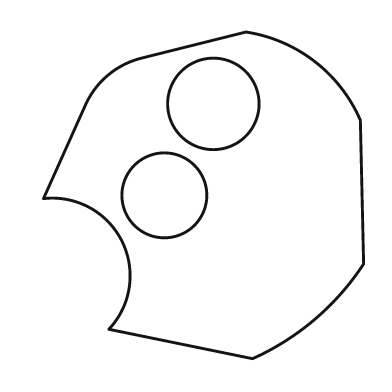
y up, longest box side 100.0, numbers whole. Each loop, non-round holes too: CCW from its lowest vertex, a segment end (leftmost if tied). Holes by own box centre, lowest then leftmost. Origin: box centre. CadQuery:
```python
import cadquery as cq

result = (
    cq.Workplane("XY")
    .moveTo(15.0, -50.0)
    .threePointArc((34.0, -38.0), (49.0, -21.0))
    .lineTo(48.0, 23.0)
    .threePointArc((34.0, 41.0), (13.0, 50.0))
    .lineTo(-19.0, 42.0)
    .threePointArc((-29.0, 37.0), (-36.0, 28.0))
    .lineTo(-49.0, -1.0)
    .threePointArc((-25.0, -14.0), (-29.0, -41.0))
    .close()
    .moveTo(-12.0, 0.0)
    .circle(13.0)
    .moveTo(3.0, 28.0)
    .circle(14.0)
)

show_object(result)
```